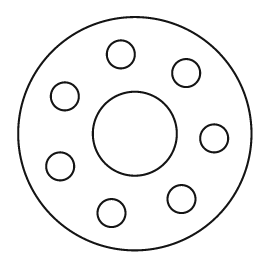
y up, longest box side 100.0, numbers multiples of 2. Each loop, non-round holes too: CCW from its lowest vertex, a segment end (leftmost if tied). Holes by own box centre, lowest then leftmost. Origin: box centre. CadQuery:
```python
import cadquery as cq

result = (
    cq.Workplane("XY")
    .moveTo(0.0, 0.0)
    .circle(50.0)
    .moveTo(-10.0, -34.0)
    .circle(6.0)
    .moveTo(20.0, -28.0)
    .circle(6.0)
    .moveTo(-32.0, -14.0)
    .circle(6.0)
    .moveTo(34.0, -2.0)
    .circle(6.0)
    .moveTo(0.0, 0.0)
    .circle(18.0)
    .moveTo(-30.0, 16.0)
    .circle(6.0)
    .moveTo(22.0, 26.0)
    .circle(6.0)
    .moveTo(-6.0, 34.0)
    .circle(6.0)
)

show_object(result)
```